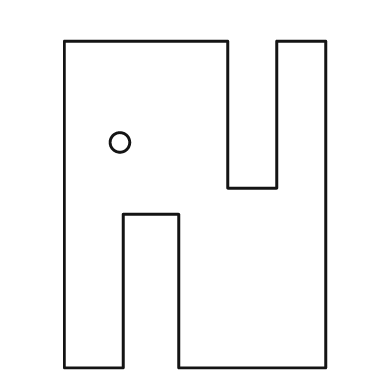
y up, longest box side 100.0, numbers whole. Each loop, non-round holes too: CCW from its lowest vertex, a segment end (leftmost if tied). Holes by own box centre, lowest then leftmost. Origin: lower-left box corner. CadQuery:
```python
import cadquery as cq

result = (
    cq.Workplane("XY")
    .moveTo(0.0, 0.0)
    .lineTo(18.0, 0.0)
    .lineTo(18.0, 47.0)
    .lineTo(35.0, 47.0)
    .lineTo(35.0, 0.0)
    .lineTo(80.0, 0.0)
    .lineTo(80.0, 100.0)
    .lineTo(65.0, 100.0)
    .lineTo(65.0, 55.0)
    .lineTo(50.0, 55.0)
    .lineTo(50.0, 100.0)
    .lineTo(0.0, 100.0)
    .close()
    .moveTo(17.0, 69.0)
    .circle(3.0)
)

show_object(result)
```